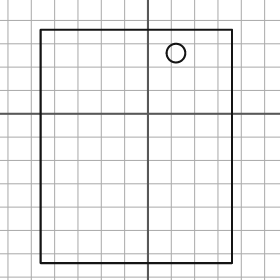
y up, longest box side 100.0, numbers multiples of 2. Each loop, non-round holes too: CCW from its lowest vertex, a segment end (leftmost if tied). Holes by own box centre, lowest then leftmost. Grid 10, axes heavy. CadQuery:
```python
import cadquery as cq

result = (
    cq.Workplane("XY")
    .moveTo(-46.0, -64.0)
    .lineTo(36.0, -64.0)
    .lineTo(36.0, 36.0)
    .lineTo(-46.0, 36.0)
    .close()
    .moveTo(12.0, 26.0)
    .circle(4.0)
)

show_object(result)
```